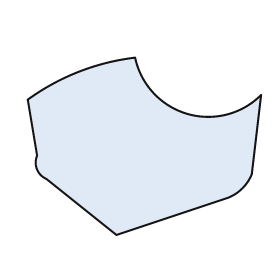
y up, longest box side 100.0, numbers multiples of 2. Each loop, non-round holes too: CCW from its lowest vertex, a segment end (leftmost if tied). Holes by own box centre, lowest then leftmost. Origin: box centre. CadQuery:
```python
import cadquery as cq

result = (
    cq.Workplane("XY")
    .moveTo(-12.0, -38.0)
    .lineTo(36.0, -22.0)
    .threePointArc((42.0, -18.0), (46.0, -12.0))
    .lineTo(50.0, 22.0)
    .threePointArc((18.0, 14.0), (-4.0, 38.0))
    .threePointArc((-28.0, 32.0), (-50.0, 20.0))
    .lineTo(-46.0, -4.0)
    .threePointArc((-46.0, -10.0), (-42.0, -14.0))
    .close()
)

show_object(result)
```